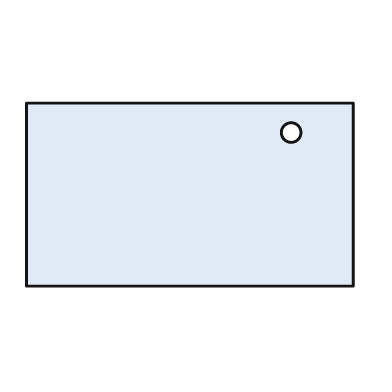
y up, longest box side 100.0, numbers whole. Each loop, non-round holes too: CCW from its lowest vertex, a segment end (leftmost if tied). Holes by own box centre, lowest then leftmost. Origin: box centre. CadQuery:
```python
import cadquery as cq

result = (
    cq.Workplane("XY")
    .moveTo(-50.0, -28.0)
    .lineTo(50.0, -28.0)
    .lineTo(50.0, 28.0)
    .lineTo(-50.0, 28.0)
    .close()
    .moveTo(31.0, 19.0)
    .circle(3.0)
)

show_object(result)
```